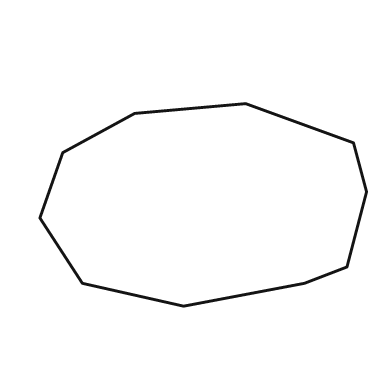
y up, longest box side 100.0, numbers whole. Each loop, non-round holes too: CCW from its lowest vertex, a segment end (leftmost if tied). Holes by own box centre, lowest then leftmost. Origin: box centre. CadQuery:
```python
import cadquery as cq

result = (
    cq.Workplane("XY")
    .moveTo(-6.0, -31.0)
    .lineTo(31.0, -24.0)
    .lineTo(44.0, -19.0)
    .lineTo(50.0, 4.0)
    .lineTo(46.0, 19.0)
    .lineTo(13.0, 31.0)
    .lineTo(-21.0, 28.0)
    .lineTo(-43.0, 16.0)
    .lineTo(-50.0, -4.0)
    .lineTo(-37.0, -24.0)
    .close()
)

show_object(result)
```